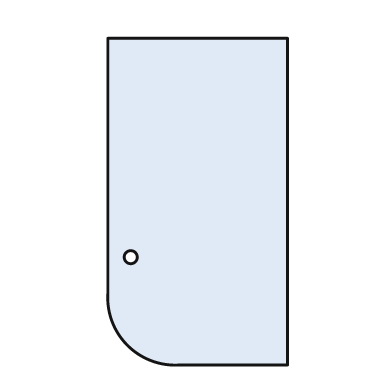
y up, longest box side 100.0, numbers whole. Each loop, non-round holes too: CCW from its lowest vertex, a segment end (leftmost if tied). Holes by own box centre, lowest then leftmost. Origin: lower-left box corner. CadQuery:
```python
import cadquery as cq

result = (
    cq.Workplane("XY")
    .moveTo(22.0, 0.0)
    .lineTo(55.0, 0.0)
    .lineTo(55.0, 100.0)
    .lineTo(0.0, 100.0)
    .lineTo(0.0, 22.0)
    .threePointArc((6.0, 6.0), (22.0, 0.0))
    .close()
    .moveTo(7.0, 33.0)
    .circle(2.0)
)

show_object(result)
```